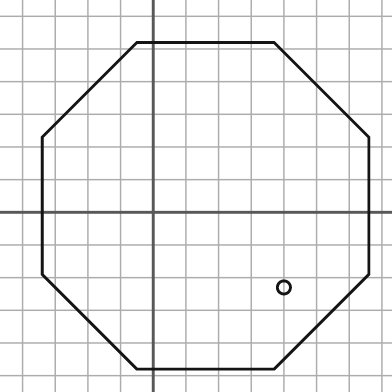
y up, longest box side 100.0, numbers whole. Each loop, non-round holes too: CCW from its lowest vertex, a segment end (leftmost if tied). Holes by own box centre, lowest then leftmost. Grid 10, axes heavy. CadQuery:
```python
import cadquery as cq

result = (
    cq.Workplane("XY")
    .moveTo(-5.0, -48.0)
    .lineTo(37.0, -48.0)
    .lineTo(66.0, -19.0)
    .lineTo(66.0, 23.0)
    .lineTo(37.0, 52.0)
    .lineTo(-5.0, 52.0)
    .lineTo(-34.0, 23.0)
    .lineTo(-34.0, -19.0)
    .close()
    .moveTo(40.0, -23.0)
    .circle(2.0)
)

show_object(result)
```